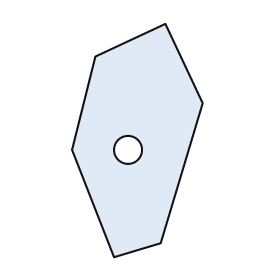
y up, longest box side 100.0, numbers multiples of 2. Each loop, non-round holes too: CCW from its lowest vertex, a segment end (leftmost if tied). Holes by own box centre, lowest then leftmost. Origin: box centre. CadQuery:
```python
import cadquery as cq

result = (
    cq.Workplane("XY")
    .moveTo(-10.0, -50.0)
    .lineTo(10.0, -44.0)
    .lineTo(28.0, 16.0)
    .lineTo(12.0, 50.0)
    .lineTo(-18.0, 36.0)
    .lineTo(-28.0, -4.0)
    .close()
    .moveTo(-4.0, -4.0)
    .circle(6.0)
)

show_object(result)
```